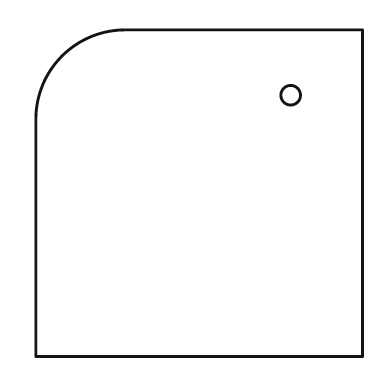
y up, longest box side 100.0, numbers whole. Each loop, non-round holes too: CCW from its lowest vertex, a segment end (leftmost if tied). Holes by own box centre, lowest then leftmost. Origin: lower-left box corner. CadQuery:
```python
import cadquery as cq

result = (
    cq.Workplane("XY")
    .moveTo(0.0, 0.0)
    .lineTo(100.0, 0.0)
    .lineTo(100.0, 100.0)
    .lineTo(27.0, 100.0)
    .threePointArc((8.0, 92.0), (0.0, 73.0))
    .close()
    .moveTo(78.0, 80.0)
    .circle(3.0)
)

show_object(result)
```